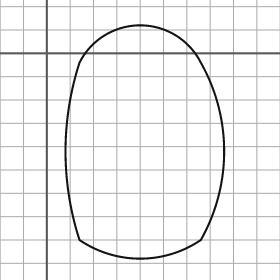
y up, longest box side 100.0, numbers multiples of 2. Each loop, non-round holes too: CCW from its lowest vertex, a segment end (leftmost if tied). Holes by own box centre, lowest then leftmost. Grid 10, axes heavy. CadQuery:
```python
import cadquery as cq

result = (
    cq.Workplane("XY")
    .moveTo(14.0, -80.0)
    .threePointArc((40.0, -88.0), (66.0, -80.0))
    .threePointArc((76.0, -42.0), (66.0, -4.0))
    .threePointArc((40.0, 12.0), (14.0, -4.0))
    .threePointArc((8.0, -42.0), (14.0, -80.0))
    .close()
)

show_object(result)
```